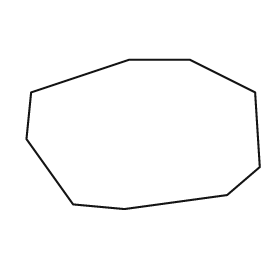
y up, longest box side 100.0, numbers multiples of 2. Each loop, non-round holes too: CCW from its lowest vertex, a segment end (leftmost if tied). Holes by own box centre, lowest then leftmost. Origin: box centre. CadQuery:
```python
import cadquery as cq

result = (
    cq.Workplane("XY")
    .moveTo(-8.0, -32.0)
    .lineTo(36.0, -26.0)
    .lineTo(50.0, -14.0)
    .lineTo(48.0, 18.0)
    .lineTo(20.0, 32.0)
    .lineTo(-6.0, 32.0)
    .lineTo(-48.0, 18.0)
    .lineTo(-50.0, -2.0)
    .lineTo(-30.0, -30.0)
    .close()
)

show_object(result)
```